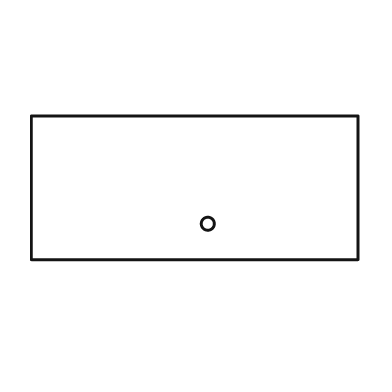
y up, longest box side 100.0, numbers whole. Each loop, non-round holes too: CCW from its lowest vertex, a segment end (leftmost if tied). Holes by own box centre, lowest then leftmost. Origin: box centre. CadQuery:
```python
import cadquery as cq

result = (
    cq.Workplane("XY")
    .moveTo(-50.0, -22.0)
    .lineTo(50.0, -22.0)
    .lineTo(50.0, 22.0)
    .lineTo(-50.0, 22.0)
    .close()
    .moveTo(4.0, -11.0)
    .circle(2.0)
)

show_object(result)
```